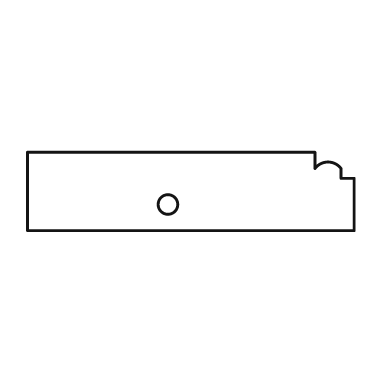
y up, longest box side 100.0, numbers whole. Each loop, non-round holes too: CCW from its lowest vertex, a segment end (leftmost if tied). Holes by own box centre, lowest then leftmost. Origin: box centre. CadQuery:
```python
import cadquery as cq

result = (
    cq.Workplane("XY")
    .moveTo(-50.0, -12.0)
    .lineTo(50.0, -12.0)
    .lineTo(50.0, 4.0)
    .lineTo(46.0, 4.0)
    .lineTo(46.0, 7.0)
    .threePointArc((42.0, 9.0), (38.0, 7.0))
    .lineTo(38.0, 12.0)
    .lineTo(-50.0, 12.0)
    .close()
    .moveTo(-7.0, -4.0)
    .circle(3.0)
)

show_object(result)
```